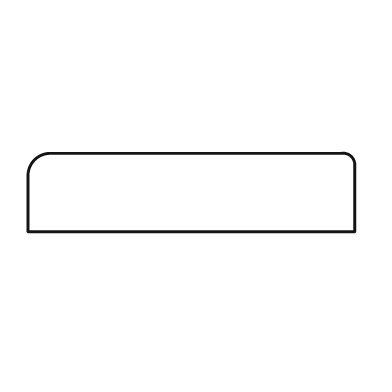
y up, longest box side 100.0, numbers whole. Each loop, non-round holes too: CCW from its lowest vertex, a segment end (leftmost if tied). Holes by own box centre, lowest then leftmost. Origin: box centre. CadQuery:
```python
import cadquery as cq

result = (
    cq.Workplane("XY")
    .moveTo(-50.0, -12.0)
    .lineTo(50.0, -12.0)
    .lineTo(50.0, 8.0)
    .threePointArc((49.0, 11.0), (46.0, 12.0))
    .lineTo(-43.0, 12.0)
    .threePointArc((-48.0, 10.0), (-50.0, 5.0))
    .close()
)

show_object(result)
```